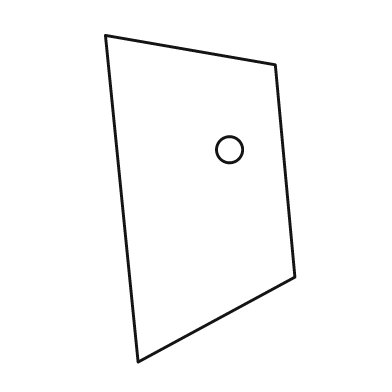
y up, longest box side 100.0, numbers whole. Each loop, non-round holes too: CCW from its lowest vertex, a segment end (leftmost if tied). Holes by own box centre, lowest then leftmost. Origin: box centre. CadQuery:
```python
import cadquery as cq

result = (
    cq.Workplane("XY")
    .moveTo(-19.0, -50.0)
    .lineTo(29.0, -24.0)
    .lineTo(23.0, 41.0)
    .lineTo(-29.0, 50.0)
    .close()
    .moveTo(9.0, 15.0)
    .circle(4.0)
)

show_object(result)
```